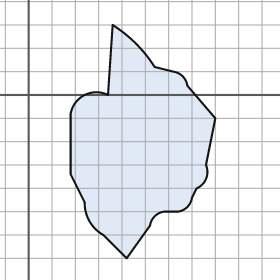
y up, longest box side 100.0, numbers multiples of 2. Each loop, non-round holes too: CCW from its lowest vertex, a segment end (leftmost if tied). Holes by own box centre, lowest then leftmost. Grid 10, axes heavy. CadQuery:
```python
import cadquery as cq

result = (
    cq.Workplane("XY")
    .moveTo(42.0, -70.0)
    .lineTo(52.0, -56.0)
    .threePointArc((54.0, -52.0), (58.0, -50.0))
    .lineTo(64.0, -50.0)
    .threePointArc((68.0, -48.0), (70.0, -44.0))
    .lineTo(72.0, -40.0)
    .threePointArc((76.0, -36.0), (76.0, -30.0))
    .lineTo(80.0, -10.0)
    .lineTo(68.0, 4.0)
    .threePointArc((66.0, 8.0), (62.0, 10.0))
    .lineTo(54.0, 12.0)
    .threePointArc((46.0, 22.0), (36.0, 30.0))
    .lineTo(34.0, 0.0)
    .threePointArc((24.0, 0.0), (18.0, -8.0))
    .lineTo(18.0, -34.0)
    .lineTo(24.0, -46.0)
    .threePointArc((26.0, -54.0), (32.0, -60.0))
    .close()
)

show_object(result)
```